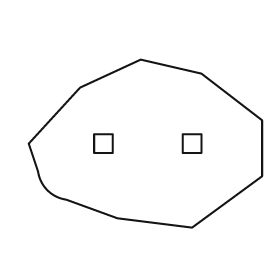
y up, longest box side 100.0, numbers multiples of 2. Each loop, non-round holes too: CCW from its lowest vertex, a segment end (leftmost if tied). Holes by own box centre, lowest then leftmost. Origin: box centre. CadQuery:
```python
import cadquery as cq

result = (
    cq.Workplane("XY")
    .moveTo(20.0, -36.0)
    .lineTo(50.0, -14.0)
    .lineTo(50.0, 10.0)
    .lineTo(24.0, 30.0)
    .lineTo(-2.0, 36.0)
    .lineTo(-28.0, 24.0)
    .lineTo(-50.0, 0.0)
    .lineTo(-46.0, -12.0)
    .threePointArc((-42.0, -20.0), (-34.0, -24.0))
    .lineTo(-12.0, -32.0)
    .close()
    .moveTo(-22.0, -4.0)
    .lineTo(-14.0, -4.0)
    .lineTo(-14.0, 4.0)
    .lineTo(-22.0, 4.0)
    .close()
    .moveTo(16.0, -4.0)
    .lineTo(24.0, -4.0)
    .lineTo(24.0, 4.0)
    .lineTo(16.0, 4.0)
    .close()
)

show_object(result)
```